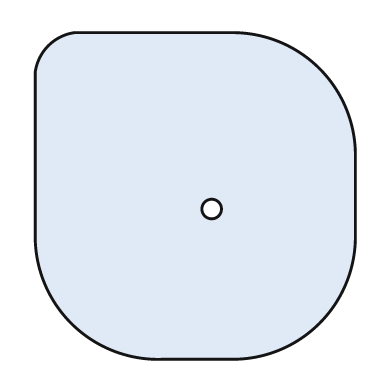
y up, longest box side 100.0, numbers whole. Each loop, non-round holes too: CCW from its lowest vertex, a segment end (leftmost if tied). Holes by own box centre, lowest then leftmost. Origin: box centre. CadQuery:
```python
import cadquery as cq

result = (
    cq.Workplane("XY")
    .moveTo(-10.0, -50.0)
    .lineTo(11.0, -50.0)
    .threePointArc((38.0, -39.0), (49.0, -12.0))
    .lineTo(49.0, 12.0)
    .threePointArc((38.0, 39.0), (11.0, 50.0))
    .lineTo(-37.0, 50.0)
    .threePointArc((-45.0, 46.0), (-49.0, 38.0))
    .lineTo(-49.0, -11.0)
    .threePointArc((-38.0, -39.0), (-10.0, -50.0))
    .close()
    .moveTo(5.0, -4.0)
    .circle(3.0)
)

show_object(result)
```